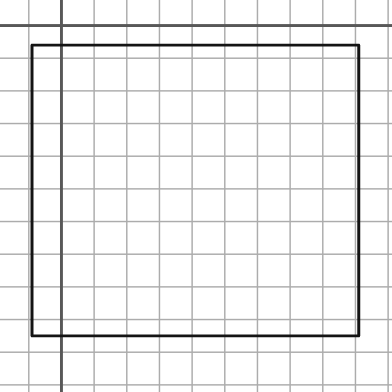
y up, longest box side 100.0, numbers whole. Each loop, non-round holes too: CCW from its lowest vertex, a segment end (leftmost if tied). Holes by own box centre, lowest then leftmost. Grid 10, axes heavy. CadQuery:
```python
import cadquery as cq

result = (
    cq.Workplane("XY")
    .moveTo(-9.0, -95.0)
    .lineTo(91.0, -95.0)
    .lineTo(91.0, -6.0)
    .lineTo(-9.0, -6.0)
    .close()
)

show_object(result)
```